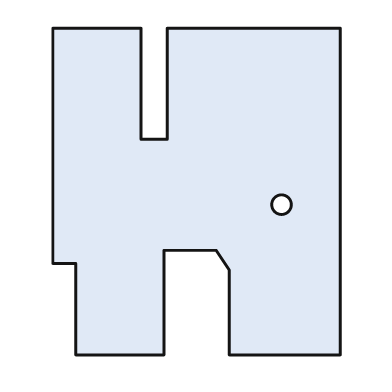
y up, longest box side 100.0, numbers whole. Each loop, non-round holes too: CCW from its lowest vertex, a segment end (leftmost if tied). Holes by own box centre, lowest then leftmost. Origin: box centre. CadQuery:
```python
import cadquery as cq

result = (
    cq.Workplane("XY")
    .moveTo(-37.0, -50.0)
    .lineTo(-10.0, -50.0)
    .lineTo(-10.0, -18.0)
    .lineTo(6.0, -18.0)
    .lineTo(10.0, -24.0)
    .lineTo(10.0, -50.0)
    .lineTo(44.0, -50.0)
    .lineTo(44.0, 50.0)
    .lineTo(-9.0, 50.0)
    .lineTo(-9.0, 16.0)
    .lineTo(-17.0, 16.0)
    .lineTo(-17.0, 50.0)
    .lineTo(-44.0, 50.0)
    .lineTo(-44.0, -22.0)
    .lineTo(-37.0, -22.0)
    .close()
    .moveTo(26.0, -4.0)
    .circle(3.0)
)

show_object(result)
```